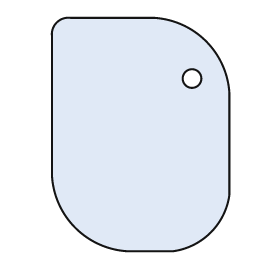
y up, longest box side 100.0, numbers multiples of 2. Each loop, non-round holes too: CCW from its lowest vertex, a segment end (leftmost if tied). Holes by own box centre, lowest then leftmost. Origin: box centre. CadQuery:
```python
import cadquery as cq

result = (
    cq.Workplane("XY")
    .moveTo(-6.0, -50.0)
    .lineTo(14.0, -50.0)
    .threePointArc((30.0, -42.0), (38.0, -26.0))
    .lineTo(38.0, 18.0)
    .threePointArc((28.0, 40.0), (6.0, 50.0))
    .lineTo(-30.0, 50.0)
    .threePointArc((-36.0, 48.0), (-38.0, 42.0))
    .lineTo(-38.0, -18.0)
    .threePointArc((-28.0, -40.0), (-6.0, -50.0))
    .close()
    .moveTo(22.0, 24.0)
    .circle(4.0)
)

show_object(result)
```